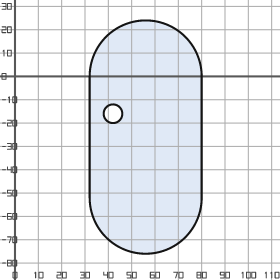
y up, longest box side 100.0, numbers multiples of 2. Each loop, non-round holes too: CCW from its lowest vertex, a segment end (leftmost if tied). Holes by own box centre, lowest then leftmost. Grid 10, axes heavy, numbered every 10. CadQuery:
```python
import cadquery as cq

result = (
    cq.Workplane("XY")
    .moveTo(32.0, -52.0)
    .threePointArc((56.0, -76.0), (80.0, -52.0))
    .lineTo(80.0, 0.0)
    .threePointArc((56.0, 24.0), (32.0, 0.0))
    .close()
    .moveTo(42.0, -16.0)
    .circle(4.0)
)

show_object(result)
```